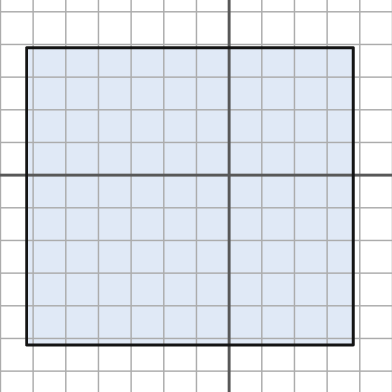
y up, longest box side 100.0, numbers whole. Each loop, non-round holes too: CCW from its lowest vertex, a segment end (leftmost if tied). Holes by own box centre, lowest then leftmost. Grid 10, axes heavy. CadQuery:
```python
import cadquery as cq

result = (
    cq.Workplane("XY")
    .moveTo(-62.0, -52.0)
    .lineTo(38.0, -52.0)
    .lineTo(38.0, 39.0)
    .lineTo(-62.0, 39.0)
    .close()
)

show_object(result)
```